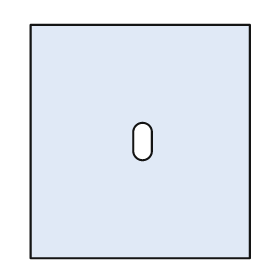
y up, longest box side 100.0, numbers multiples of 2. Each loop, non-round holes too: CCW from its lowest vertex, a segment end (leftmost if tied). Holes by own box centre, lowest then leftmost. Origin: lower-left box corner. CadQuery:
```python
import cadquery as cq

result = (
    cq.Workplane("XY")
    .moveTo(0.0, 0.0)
    .lineTo(94.0, 0.0)
    .lineTo(94.0, 100.0)
    .lineTo(0.0, 100.0)
    .close()
    .moveTo(44.0, 46.0)
    .threePointArc((48.0, 42.0), (52.0, 46.0))
    .lineTo(52.0, 54.0)
    .threePointArc((48.0, 58.0), (44.0, 54.0))
    .close()
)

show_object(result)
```